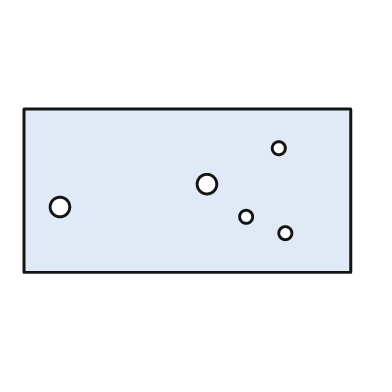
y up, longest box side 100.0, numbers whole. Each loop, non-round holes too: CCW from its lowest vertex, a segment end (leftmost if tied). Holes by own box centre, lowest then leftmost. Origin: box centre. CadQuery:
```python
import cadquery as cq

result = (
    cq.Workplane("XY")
    .moveTo(-50.0, -25.0)
    .lineTo(50.0, -25.0)
    .lineTo(50.0, 25.0)
    .lineTo(-50.0, 25.0)
    .close()
    .moveTo(30.0, -13.0)
    .circle(2.0)
    .moveTo(18.0, -8.0)
    .circle(2.0)
    .moveTo(-39.0, -5.0)
    .circle(3.0)
    .moveTo(6.0, 2.0)
    .circle(3.0)
    .moveTo(28.0, 13.0)
    .circle(2.0)
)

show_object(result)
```